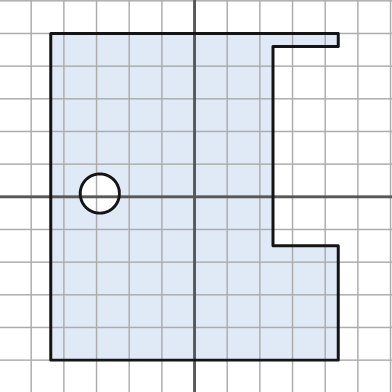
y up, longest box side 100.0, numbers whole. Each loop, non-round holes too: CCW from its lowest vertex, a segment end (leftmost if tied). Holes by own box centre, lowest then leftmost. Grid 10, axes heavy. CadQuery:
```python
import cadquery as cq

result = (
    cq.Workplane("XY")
    .moveTo(-44.0, -50.0)
    .lineTo(44.0, -50.0)
    .lineTo(44.0, -15.0)
    .lineTo(24.0, -15.0)
    .lineTo(24.0, 46.0)
    .lineTo(44.0, 46.0)
    .lineTo(44.0, 50.0)
    .lineTo(-44.0, 50.0)
    .close()
    .moveTo(-29.0, 1.0)
    .circle(6.0)
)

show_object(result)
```